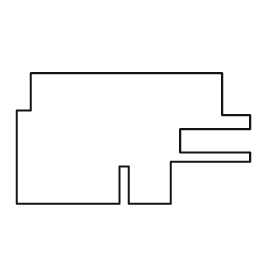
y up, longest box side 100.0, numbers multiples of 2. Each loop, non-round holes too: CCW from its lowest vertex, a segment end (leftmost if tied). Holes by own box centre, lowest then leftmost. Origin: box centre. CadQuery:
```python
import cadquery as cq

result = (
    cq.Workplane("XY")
    .moveTo(-50.0, -28.0)
    .lineTo(-6.0, -28.0)
    .lineTo(-6.0, -12.0)
    .lineTo(-2.0, -12.0)
    .lineTo(-2.0, -28.0)
    .lineTo(16.0, -28.0)
    .lineTo(16.0, -10.0)
    .lineTo(50.0, -10.0)
    .lineTo(50.0, -6.0)
    .lineTo(20.0, -6.0)
    .lineTo(20.0, 4.0)
    .lineTo(50.0, 4.0)
    .lineTo(50.0, 10.0)
    .lineTo(38.0, 10.0)
    .lineTo(38.0, 28.0)
    .lineTo(-44.0, 28.0)
    .lineTo(-44.0, 12.0)
    .lineTo(-50.0, 12.0)
    .close()
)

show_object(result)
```